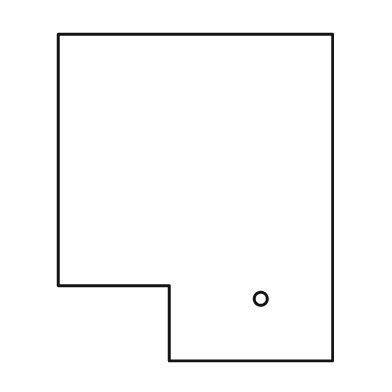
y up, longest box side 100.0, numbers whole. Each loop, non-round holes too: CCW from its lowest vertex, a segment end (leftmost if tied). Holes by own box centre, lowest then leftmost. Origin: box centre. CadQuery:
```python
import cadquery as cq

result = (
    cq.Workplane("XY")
    .moveTo(-8.0, -50.0)
    .lineTo(42.0, -50.0)
    .lineTo(42.0, 50.0)
    .lineTo(-42.0, 50.0)
    .lineTo(-42.0, -27.0)
    .lineTo(-8.0, -27.0)
    .close()
    .moveTo(20.0, -31.0)
    .circle(2.0)
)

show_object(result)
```